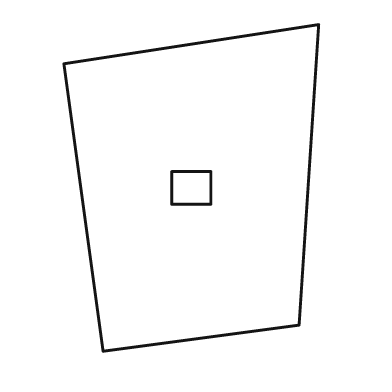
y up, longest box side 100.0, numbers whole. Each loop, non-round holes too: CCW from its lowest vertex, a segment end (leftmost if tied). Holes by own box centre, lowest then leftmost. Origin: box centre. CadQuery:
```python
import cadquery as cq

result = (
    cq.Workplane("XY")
    .moveTo(-27.0, -50.0)
    .lineTo(33.0, -42.0)
    .lineTo(39.0, 50.0)
    .lineTo(-39.0, 38.0)
    .close()
    .moveTo(-6.0, -5.0)
    .lineTo(6.0, -5.0)
    .lineTo(6.0, 5.0)
    .lineTo(-6.0, 5.0)
    .close()
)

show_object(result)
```